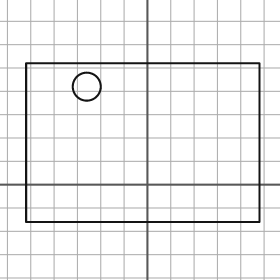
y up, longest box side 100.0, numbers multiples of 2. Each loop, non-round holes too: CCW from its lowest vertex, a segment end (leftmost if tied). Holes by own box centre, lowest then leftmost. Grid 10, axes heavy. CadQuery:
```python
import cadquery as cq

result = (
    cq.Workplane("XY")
    .moveTo(-52.0, -16.0)
    .lineTo(48.0, -16.0)
    .lineTo(48.0, 52.0)
    .lineTo(-52.0, 52.0)
    .close()
    .moveTo(-26.0, 42.0)
    .circle(6.0)
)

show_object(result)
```